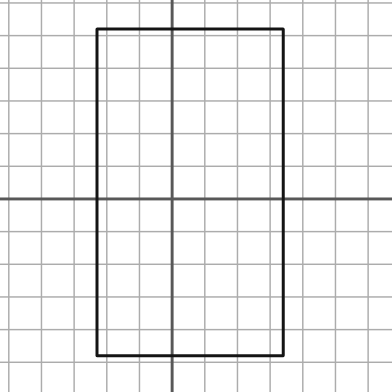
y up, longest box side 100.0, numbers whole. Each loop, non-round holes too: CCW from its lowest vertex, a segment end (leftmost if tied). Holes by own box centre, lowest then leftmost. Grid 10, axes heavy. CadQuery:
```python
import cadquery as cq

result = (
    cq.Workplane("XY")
    .moveTo(-23.0, -48.0)
    .lineTo(34.0, -48.0)
    .lineTo(34.0, 52.0)
    .lineTo(-23.0, 52.0)
    .close()
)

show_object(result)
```